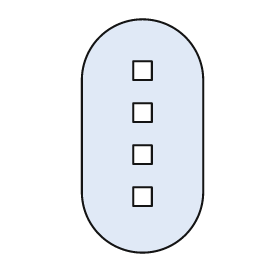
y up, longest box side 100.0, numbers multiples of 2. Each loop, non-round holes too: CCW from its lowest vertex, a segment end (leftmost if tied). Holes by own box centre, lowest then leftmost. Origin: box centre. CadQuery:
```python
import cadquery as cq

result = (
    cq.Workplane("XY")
    .moveTo(-26.0, -24.0)
    .threePointArc((0.0, -50.0), (26.0, -24.0))
    .lineTo(26.0, 24.0)
    .threePointArc((0.0, 50.0), (-26.0, 24.0))
    .close()
    .moveTo(-4.0, -30.0)
    .lineTo(4.0, -30.0)
    .lineTo(4.0, -22.0)
    .lineTo(-4.0, -22.0)
    .close()
    .moveTo(-4.0, -12.0)
    .lineTo(4.0, -12.0)
    .lineTo(4.0, -4.0)
    .lineTo(-4.0, -4.0)
    .close()
    .moveTo(-4.0, 6.0)
    .lineTo(4.0, 6.0)
    .lineTo(4.0, 14.0)
    .lineTo(-4.0, 14.0)
    .close()
    .moveTo(-4.0, 24.0)
    .lineTo(4.0, 24.0)
    .lineTo(4.0, 32.0)
    .lineTo(-4.0, 32.0)
    .close()
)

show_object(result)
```